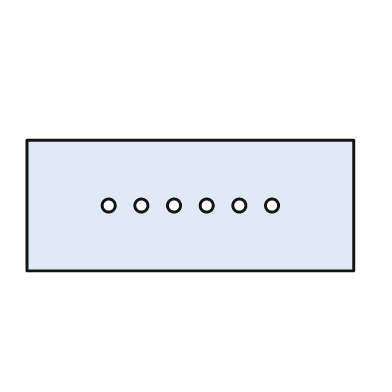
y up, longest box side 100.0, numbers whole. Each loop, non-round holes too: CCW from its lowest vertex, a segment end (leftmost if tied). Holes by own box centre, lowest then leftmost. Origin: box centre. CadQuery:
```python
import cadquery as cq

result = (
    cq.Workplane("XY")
    .moveTo(-50.0, -20.0)
    .lineTo(50.0, -20.0)
    .lineTo(50.0, 20.0)
    .lineTo(-50.0, 20.0)
    .close()
    .moveTo(-25.0, 0.0)
    .circle(2.0)
    .moveTo(-15.0, 0.0)
    .circle(2.0)
    .moveTo(-5.0, 0.0)
    .circle(2.0)
    .moveTo(5.0, 0.0)
    .circle(2.0)
    .moveTo(15.0, 0.0)
    .circle(2.0)
    .moveTo(25.0, 0.0)
    .circle(2.0)
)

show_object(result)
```